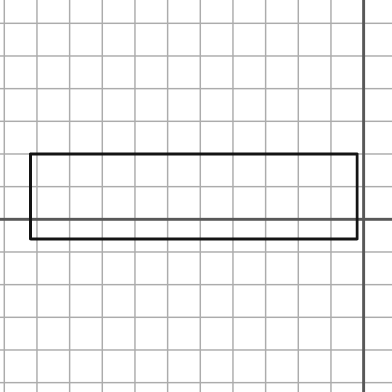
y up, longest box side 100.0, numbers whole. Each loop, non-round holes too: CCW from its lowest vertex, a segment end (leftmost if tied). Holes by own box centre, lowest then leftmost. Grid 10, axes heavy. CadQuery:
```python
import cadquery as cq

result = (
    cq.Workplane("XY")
    .moveTo(-102.0, -6.0)
    .lineTo(-2.0, -6.0)
    .lineTo(-2.0, 20.0)
    .lineTo(-102.0, 20.0)
    .close()
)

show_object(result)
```